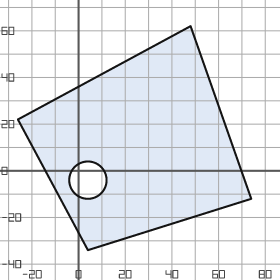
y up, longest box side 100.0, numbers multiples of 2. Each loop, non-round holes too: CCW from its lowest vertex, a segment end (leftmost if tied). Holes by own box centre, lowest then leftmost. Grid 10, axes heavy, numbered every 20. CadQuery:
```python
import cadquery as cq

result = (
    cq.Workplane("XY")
    .moveTo(4.0, -34.0)
    .lineTo(74.0, -12.0)
    .lineTo(48.0, 62.0)
    .lineTo(-26.0, 22.0)
    .close()
    .moveTo(4.0, -4.0)
    .circle(8.0)
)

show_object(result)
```